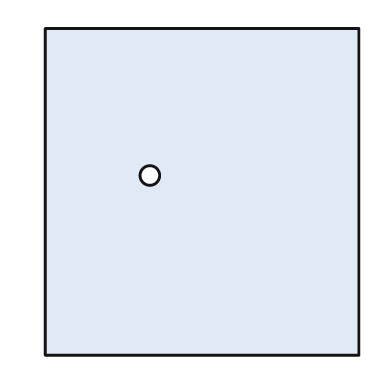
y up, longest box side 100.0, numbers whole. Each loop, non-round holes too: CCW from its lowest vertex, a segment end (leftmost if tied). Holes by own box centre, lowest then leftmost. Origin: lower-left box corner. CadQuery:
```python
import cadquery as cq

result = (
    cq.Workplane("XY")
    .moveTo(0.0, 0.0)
    .lineTo(96.0, 0.0)
    .lineTo(96.0, 100.0)
    .lineTo(0.0, 100.0)
    .close()
    .moveTo(32.0, 55.0)
    .circle(3.0)
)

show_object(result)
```